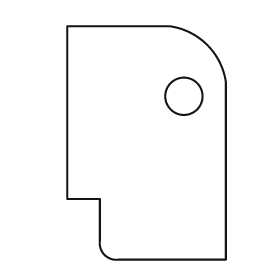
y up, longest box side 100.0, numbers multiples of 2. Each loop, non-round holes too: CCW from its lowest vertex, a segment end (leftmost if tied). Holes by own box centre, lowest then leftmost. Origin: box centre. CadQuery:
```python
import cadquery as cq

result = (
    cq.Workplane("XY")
    .moveTo(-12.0, -50.0)
    .lineTo(34.0, -50.0)
    .lineTo(34.0, 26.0)
    .threePointArc((26.0, 42.0), (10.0, 50.0))
    .lineTo(-34.0, 50.0)
    .lineTo(-34.0, -24.0)
    .lineTo(-20.0, -24.0)
    .lineTo(-20.0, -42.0)
    .threePointArc((-18.0, -48.0), (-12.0, -50.0))
    .close()
    .moveTo(16.0, 20.0)
    .circle(8.0)
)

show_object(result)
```